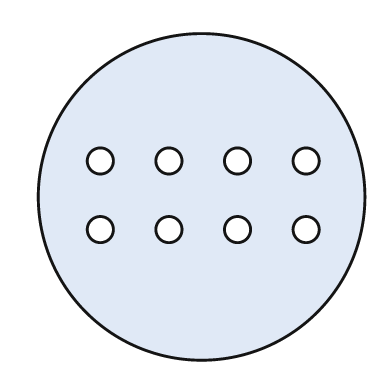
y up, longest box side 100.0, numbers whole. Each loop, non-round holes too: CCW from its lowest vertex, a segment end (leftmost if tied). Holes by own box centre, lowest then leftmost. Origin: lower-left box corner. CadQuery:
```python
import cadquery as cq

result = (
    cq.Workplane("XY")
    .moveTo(50.0, 50.0)
    .circle(50.0)
    .moveTo(19.0, 40.0)
    .circle(4.0)
    .moveTo(40.0, 40.0)
    .circle(4.0)
    .moveTo(61.0, 40.0)
    .circle(4.0)
    .moveTo(82.0, 40.0)
    .circle(4.0)
    .moveTo(19.0, 61.0)
    .circle(4.0)
    .moveTo(40.0, 61.0)
    .circle(4.0)
    .moveTo(61.0, 61.0)
    .circle(4.0)
    .moveTo(82.0, 61.0)
    .circle(4.0)
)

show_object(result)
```